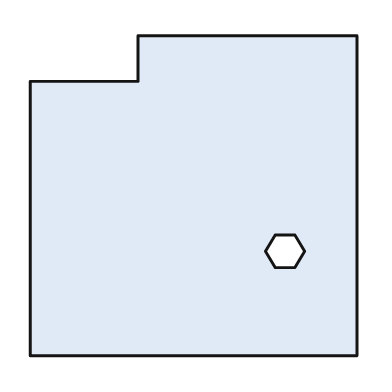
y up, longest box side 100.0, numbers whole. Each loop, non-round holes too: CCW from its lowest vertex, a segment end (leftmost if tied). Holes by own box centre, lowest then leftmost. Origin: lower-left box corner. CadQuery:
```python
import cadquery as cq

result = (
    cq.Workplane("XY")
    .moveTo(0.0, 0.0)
    .lineTo(100.0, 0.0)
    .lineTo(100.0, 98.0)
    .lineTo(33.0, 98.0)
    .lineTo(33.0, 84.0)
    .lineTo(0.0, 84.0)
    .close()
    .moveTo(75.0, 27.0)
    .lineTo(81.0, 27.0)
    .lineTo(84.0, 32.0)
    .lineTo(81.0, 37.0)
    .lineTo(75.0, 37.0)
    .lineTo(72.0, 32.0)
    .close()
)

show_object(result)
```